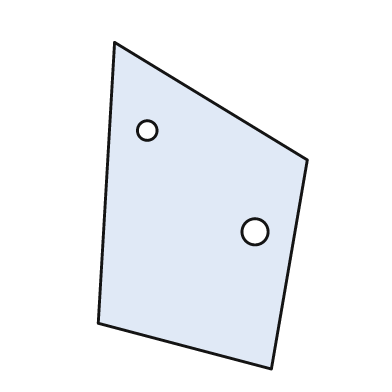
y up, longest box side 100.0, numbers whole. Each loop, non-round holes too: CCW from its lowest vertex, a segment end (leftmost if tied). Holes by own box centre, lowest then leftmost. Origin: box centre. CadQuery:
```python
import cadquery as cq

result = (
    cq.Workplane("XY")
    .moveTo(21.0, -50.0)
    .lineTo(32.0, 14.0)
    .lineTo(-27.0, 50.0)
    .lineTo(-32.0, -36.0)
    .close()
    .moveTo(16.0, -8.0)
    .circle(4.0)
    .moveTo(-17.0, 23.0)
    .circle(3.0)
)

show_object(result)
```